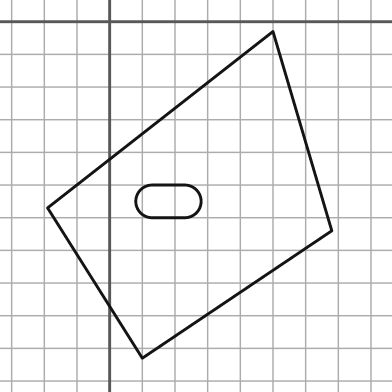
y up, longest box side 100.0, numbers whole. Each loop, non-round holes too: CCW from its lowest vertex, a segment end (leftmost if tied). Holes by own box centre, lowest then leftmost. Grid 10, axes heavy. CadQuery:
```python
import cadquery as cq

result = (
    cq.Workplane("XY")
    .moveTo(10.0, -103.0)
    .lineTo(68.0, -64.0)
    .lineTo(50.0, -3.0)
    .lineTo(-19.0, -57.0)
    .close()
    .moveTo(13.0, -60.0)
    .lineTo(23.0, -60.0)
    .threePointArc((28.0, -55.0), (23.0, -50.0))
    .lineTo(13.0, -50.0)
    .threePointArc((8.0, -55.0), (13.0, -60.0))
    .close()
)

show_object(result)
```